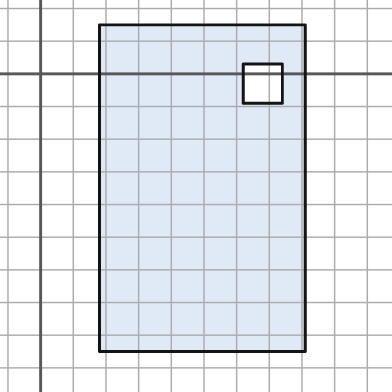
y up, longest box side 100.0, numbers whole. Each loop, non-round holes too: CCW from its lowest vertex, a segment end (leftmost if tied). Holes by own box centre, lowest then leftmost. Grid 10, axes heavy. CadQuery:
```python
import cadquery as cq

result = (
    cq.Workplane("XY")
    .moveTo(18.0, -85.0)
    .lineTo(81.0, -85.0)
    .lineTo(81.0, 15.0)
    .lineTo(18.0, 15.0)
    .close()
    .moveTo(62.0, -9.0)
    .lineTo(74.0, -9.0)
    .lineTo(74.0, 3.0)
    .lineTo(62.0, 3.0)
    .close()
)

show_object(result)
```